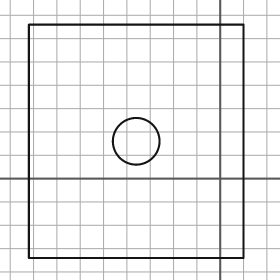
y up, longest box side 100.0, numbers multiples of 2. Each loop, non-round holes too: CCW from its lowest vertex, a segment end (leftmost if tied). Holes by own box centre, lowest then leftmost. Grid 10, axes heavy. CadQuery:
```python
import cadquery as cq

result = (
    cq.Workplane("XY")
    .moveTo(-82.0, -34.0)
    .lineTo(10.0, -34.0)
    .lineTo(10.0, 66.0)
    .lineTo(-82.0, 66.0)
    .close()
    .moveTo(-36.0, 16.0)
    .circle(10.0)
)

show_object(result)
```